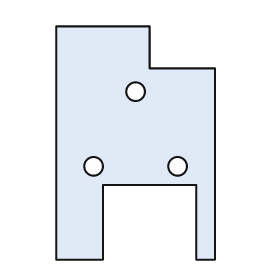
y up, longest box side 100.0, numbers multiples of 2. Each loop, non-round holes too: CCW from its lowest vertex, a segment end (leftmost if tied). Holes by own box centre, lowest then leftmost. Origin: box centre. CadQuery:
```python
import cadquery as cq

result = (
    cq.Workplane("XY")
    .moveTo(-34.0, -50.0)
    .lineTo(-14.0, -50.0)
    .lineTo(-14.0, -18.0)
    .lineTo(26.0, -18.0)
    .lineTo(26.0, -50.0)
    .lineTo(34.0, -50.0)
    .lineTo(34.0, 32.0)
    .lineTo(6.0, 32.0)
    .lineTo(6.0, 50.0)
    .lineTo(-34.0, 50.0)
    .close()
    .moveTo(-18.0, -10.0)
    .circle(4.0)
    .moveTo(18.0, -10.0)
    .circle(4.0)
    .moveTo(0.0, 22.0)
    .circle(4.0)
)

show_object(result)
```